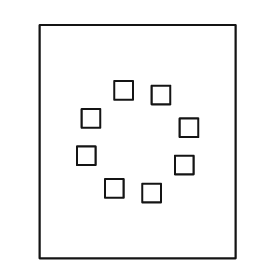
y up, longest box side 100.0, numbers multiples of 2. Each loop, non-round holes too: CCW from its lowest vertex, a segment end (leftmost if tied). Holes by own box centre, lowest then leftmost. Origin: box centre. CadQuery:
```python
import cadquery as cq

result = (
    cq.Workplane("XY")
    .moveTo(-42.0, -50.0)
    .lineTo(42.0, -50.0)
    .lineTo(42.0, 50.0)
    .lineTo(-42.0, 50.0)
    .close()
    .moveTo(2.0, -26.0)
    .lineTo(10.0, -26.0)
    .lineTo(10.0, -18.0)
    .lineTo(2.0, -18.0)
    .close()
    .moveTo(-14.0, -24.0)
    .lineTo(-6.0, -24.0)
    .lineTo(-6.0, -16.0)
    .lineTo(-14.0, -16.0)
    .close()
    .moveTo(16.0, -14.0)
    .lineTo(24.0, -14.0)
    .lineTo(24.0, -6.0)
    .lineTo(16.0, -6.0)
    .close()
    .moveTo(-26.0, -10.0)
    .lineTo(-18.0, -10.0)
    .lineTo(-18.0, -2.0)
    .lineTo(-26.0, -2.0)
    .close()
    .moveTo(18.0, 2.0)
    .lineTo(26.0, 2.0)
    .lineTo(26.0, 10.0)
    .lineTo(18.0, 10.0)
    .close()
    .moveTo(-24.0, 6.0)
    .lineTo(-16.0, 6.0)
    .lineTo(-16.0, 14.0)
    .lineTo(-24.0, 14.0)
    .close()
    .moveTo(6.0, 16.0)
    .lineTo(14.0, 16.0)
    .lineTo(14.0, 24.0)
    .lineTo(6.0, 24.0)
    .close()
    .moveTo(-10.0, 18.0)
    .lineTo(-2.0, 18.0)
    .lineTo(-2.0, 26.0)
    .lineTo(-10.0, 26.0)
    .close()
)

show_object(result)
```